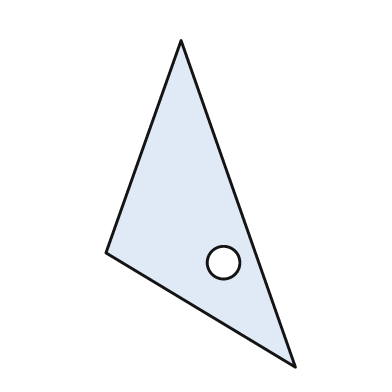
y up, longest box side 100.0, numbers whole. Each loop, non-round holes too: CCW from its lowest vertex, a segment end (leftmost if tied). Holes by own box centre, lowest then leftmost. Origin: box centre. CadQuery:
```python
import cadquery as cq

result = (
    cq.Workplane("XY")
    .moveTo(29.0, -50.0)
    .lineTo(-6.0, 50.0)
    .lineTo(-29.0, -15.0)
    .close()
    .moveTo(7.0, -18.0)
    .circle(5.0)
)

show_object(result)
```